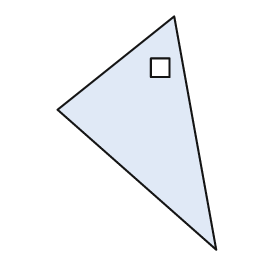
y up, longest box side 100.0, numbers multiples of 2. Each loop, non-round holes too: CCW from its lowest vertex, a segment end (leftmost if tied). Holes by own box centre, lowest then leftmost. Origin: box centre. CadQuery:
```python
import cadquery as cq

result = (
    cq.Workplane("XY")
    .moveTo(34.0, -50.0)
    .lineTo(16.0, 50.0)
    .lineTo(-34.0, 10.0)
    .close()
    .moveTo(6.0, 24.0)
    .lineTo(14.0, 24.0)
    .lineTo(14.0, 32.0)
    .lineTo(6.0, 32.0)
    .close()
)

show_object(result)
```